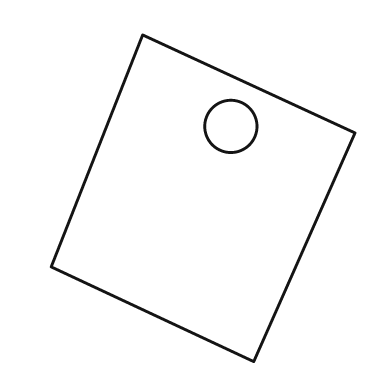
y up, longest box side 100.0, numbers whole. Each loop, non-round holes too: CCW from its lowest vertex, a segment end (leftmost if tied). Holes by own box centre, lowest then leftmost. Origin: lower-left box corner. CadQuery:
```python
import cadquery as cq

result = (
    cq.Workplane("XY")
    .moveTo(62.0, 0.0)
    .lineTo(93.0, 70.0)
    .lineTo(28.0, 100.0)
    .lineTo(0.0, 29.0)
    .close()
    .moveTo(55.0, 72.0)
    .circle(8.0)
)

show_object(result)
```